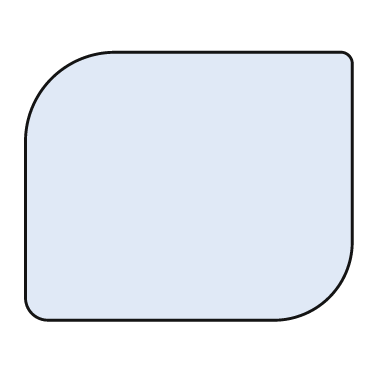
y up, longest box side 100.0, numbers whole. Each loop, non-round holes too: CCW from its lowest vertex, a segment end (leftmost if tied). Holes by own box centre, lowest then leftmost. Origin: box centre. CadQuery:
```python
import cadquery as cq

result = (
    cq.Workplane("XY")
    .moveTo(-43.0, -41.0)
    .lineTo(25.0, -41.0)
    .threePointArc((43.0, -34.0), (50.0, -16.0))
    .lineTo(50.0, 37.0)
    .threePointArc((49.0, 40.0), (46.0, 41.0))
    .lineTo(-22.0, 41.0)
    .threePointArc((-42.0, 33.0), (-50.0, 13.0))
    .lineTo(-50.0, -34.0)
    .threePointArc((-48.0, -39.0), (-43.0, -41.0))
    .close()
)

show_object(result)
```